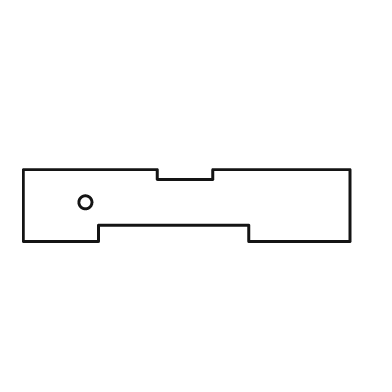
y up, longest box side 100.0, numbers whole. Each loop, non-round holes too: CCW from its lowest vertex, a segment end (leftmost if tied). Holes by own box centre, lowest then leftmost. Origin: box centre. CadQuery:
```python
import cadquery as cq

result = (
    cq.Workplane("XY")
    .moveTo(-50.0, -11.0)
    .lineTo(-27.0, -11.0)
    .lineTo(-27.0, -6.0)
    .lineTo(19.0, -6.0)
    .lineTo(19.0, -11.0)
    .lineTo(50.0, -11.0)
    .lineTo(50.0, 11.0)
    .lineTo(8.0, 11.0)
    .lineTo(8.0, 8.0)
    .lineTo(-9.0, 8.0)
    .lineTo(-9.0, 11.0)
    .lineTo(-50.0, 11.0)
    .close()
    .moveTo(-31.0, 1.0)
    .circle(2.0)
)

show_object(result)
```